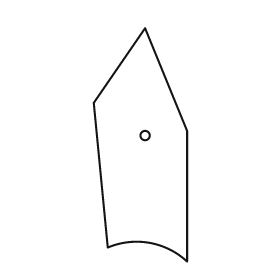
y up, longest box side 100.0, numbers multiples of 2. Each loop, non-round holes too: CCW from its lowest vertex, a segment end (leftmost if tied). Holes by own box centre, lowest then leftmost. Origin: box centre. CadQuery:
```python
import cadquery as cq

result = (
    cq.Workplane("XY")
    .moveTo(20.0, -50.0)
    .lineTo(20.0, 6.0)
    .lineTo(2.0, 50.0)
    .lineTo(-20.0, 18.0)
    .lineTo(-14.0, -44.0)
    .threePointArc((4.0, -42.0), (20.0, -50.0))
    .close()
    .moveTo(2.0, 4.0)
    .circle(2.0)
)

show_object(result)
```